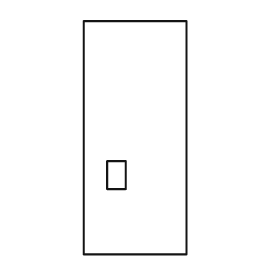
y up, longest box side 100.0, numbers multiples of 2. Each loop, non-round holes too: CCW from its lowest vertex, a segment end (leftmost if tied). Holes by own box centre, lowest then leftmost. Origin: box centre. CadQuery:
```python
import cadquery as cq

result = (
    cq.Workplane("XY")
    .moveTo(-22.0, -50.0)
    .lineTo(22.0, -50.0)
    .lineTo(22.0, 50.0)
    .lineTo(-22.0, 50.0)
    .close()
    .moveTo(-12.0, -22.0)
    .lineTo(-4.0, -22.0)
    .lineTo(-4.0, -10.0)
    .lineTo(-12.0, -10.0)
    .close()
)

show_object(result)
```